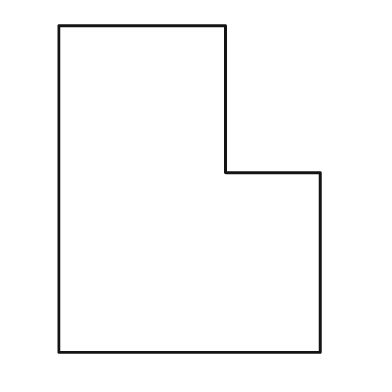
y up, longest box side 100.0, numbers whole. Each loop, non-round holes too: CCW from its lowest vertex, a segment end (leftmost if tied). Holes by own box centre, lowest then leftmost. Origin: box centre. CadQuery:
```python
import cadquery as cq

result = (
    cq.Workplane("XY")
    .moveTo(-40.0, -50.0)
    .lineTo(40.0, -50.0)
    .lineTo(40.0, 5.0)
    .lineTo(11.0, 5.0)
    .lineTo(11.0, 50.0)
    .lineTo(-40.0, 50.0)
    .close()
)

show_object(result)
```